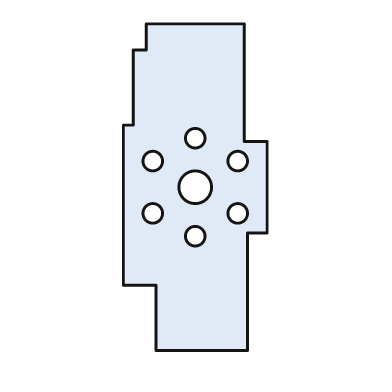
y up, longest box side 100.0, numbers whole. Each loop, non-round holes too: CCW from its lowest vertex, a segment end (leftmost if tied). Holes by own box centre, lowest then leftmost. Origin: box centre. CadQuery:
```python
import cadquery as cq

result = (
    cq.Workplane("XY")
    .moveTo(-12.0, -50.0)
    .lineTo(16.0, -50.0)
    .lineTo(16.0, -14.0)
    .lineTo(22.0, -14.0)
    .lineTo(22.0, 14.0)
    .lineTo(15.0, 14.0)
    .lineTo(15.0, 50.0)
    .lineTo(-15.0, 50.0)
    .lineTo(-15.0, 42.0)
    .lineTo(-19.0, 42.0)
    .lineTo(-19.0, 19.0)
    .lineTo(-22.0, 19.0)
    .lineTo(-22.0, -30.0)
    .lineTo(-12.0, -30.0)
    .close()
    .moveTo(0.0, -15.0)
    .circle(3.0)
    .moveTo(-13.0, -8.0)
    .circle(3.0)
    .moveTo(13.0, -8.0)
    .circle(3.0)
    .moveTo(0.0, 0.0)
    .circle(5.0)
    .moveTo(-13.0, 8.0)
    .circle(3.0)
    .moveTo(13.0, 8.0)
    .circle(3.0)
    .moveTo(0.0, 15.0)
    .circle(3.0)
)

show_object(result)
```